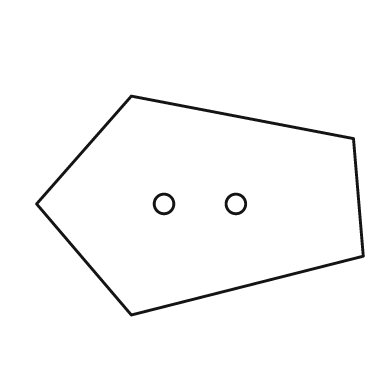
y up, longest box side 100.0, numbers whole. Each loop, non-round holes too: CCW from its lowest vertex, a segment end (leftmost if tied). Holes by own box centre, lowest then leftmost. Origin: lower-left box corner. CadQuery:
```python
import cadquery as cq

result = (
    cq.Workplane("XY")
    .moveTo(29.0, 0.0)
    .lineTo(100.0, 18.0)
    .lineTo(97.0, 54.0)
    .lineTo(29.0, 67.0)
    .lineTo(0.0, 34.0)
    .close()
    .moveTo(39.0, 34.0)
    .circle(3.0)
    .moveTo(61.0, 34.0)
    .circle(3.0)
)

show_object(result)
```